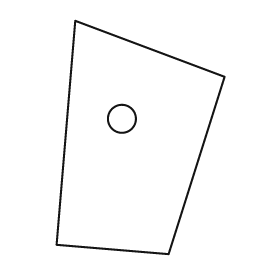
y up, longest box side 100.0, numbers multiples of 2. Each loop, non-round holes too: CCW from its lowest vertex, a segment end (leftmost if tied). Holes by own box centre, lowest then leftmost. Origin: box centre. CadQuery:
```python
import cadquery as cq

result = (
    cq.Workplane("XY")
    .moveTo(12.0, -50.0)
    .lineTo(36.0, 26.0)
    .lineTo(-28.0, 50.0)
    .lineTo(-36.0, -46.0)
    .close()
    .moveTo(-8.0, 8.0)
    .circle(6.0)
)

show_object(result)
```